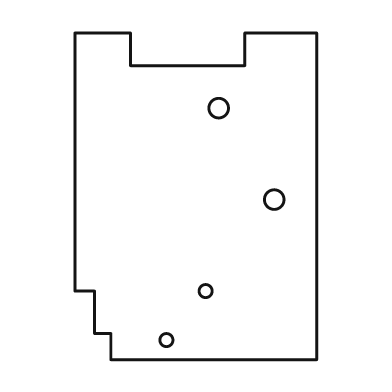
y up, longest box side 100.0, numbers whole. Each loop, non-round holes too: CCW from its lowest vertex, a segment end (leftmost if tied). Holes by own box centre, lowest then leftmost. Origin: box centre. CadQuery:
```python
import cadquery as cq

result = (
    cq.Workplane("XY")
    .moveTo(-26.0, -50.0)
    .lineTo(37.0, -50.0)
    .lineTo(37.0, 50.0)
    .lineTo(15.0, 50.0)
    .lineTo(15.0, 40.0)
    .lineTo(-20.0, 40.0)
    .lineTo(-20.0, 50.0)
    .lineTo(-37.0, 50.0)
    .lineTo(-37.0, -29.0)
    .lineTo(-31.0, -29.0)
    .lineTo(-31.0, -42.0)
    .lineTo(-26.0, -42.0)
    .close()
    .moveTo(-9.0, -44.0)
    .circle(2.0)
    .moveTo(3.0, -29.0)
    .circle(2.0)
    .moveTo(24.0, -1.0)
    .circle(3.0)
    .moveTo(7.0, 27.0)
    .circle(3.0)
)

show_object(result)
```